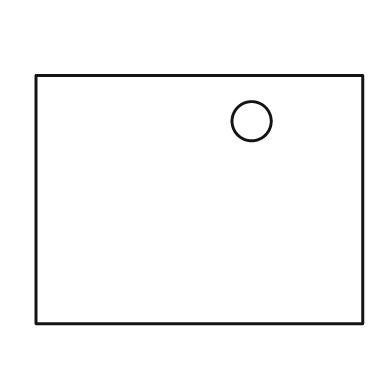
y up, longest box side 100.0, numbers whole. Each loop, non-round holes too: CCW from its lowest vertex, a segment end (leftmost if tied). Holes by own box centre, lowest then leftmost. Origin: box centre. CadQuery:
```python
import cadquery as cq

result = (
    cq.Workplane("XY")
    .moveTo(-50.0, -38.0)
    .lineTo(50.0, -38.0)
    .lineTo(50.0, 38.0)
    .lineTo(-50.0, 38.0)
    .close()
    .moveTo(16.0, 24.0)
    .circle(6.0)
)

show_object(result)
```